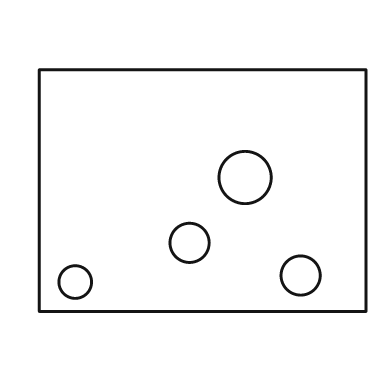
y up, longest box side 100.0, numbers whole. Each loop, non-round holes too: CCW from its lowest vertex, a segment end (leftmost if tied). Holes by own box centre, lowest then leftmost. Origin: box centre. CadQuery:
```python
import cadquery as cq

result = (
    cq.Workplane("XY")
    .moveTo(-50.0, -37.0)
    .lineTo(50.0, -37.0)
    .lineTo(50.0, 37.0)
    .lineTo(-50.0, 37.0)
    .close()
    .moveTo(-39.0, -28.0)
    .circle(5.0)
    .moveTo(30.0, -26.0)
    .circle(6.0)
    .moveTo(-4.0, -16.0)
    .circle(6.0)
    .moveTo(13.0, 4.0)
    .circle(8.0)
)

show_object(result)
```